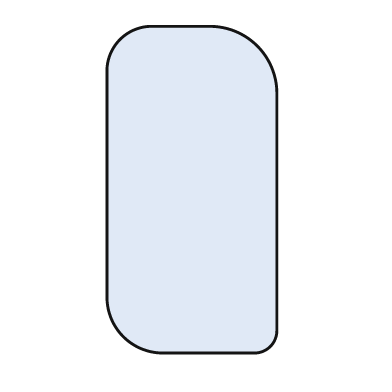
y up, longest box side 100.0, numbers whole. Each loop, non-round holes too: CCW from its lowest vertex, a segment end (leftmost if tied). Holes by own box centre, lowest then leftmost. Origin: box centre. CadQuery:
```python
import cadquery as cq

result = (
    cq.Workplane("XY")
    .moveTo(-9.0, -50.0)
    .lineTo(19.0, -50.0)
    .threePointArc((24.0, -48.0), (26.0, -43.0))
    .lineTo(26.0, 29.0)
    .threePointArc((20.0, 44.0), (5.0, 50.0))
    .lineTo(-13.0, 50.0)
    .threePointArc((-22.0, 46.0), (-26.0, 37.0))
    .lineTo(-26.0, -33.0)
    .threePointArc((-21.0, -45.0), (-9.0, -50.0))
    .close()
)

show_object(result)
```